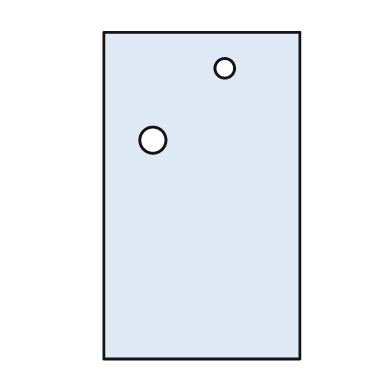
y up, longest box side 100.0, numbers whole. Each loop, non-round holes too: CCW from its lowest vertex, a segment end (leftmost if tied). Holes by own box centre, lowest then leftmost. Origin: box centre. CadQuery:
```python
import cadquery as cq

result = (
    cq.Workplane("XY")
    .moveTo(-30.0, -50.0)
    .lineTo(30.0, -50.0)
    .lineTo(30.0, 50.0)
    .lineTo(-30.0, 50.0)
    .close()
    .moveTo(-15.0, 17.0)
    .circle(4.0)
    .moveTo(7.0, 39.0)
    .circle(3.0)
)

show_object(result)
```